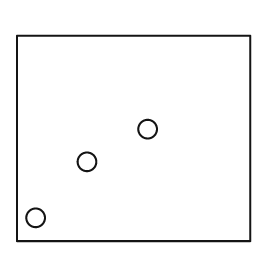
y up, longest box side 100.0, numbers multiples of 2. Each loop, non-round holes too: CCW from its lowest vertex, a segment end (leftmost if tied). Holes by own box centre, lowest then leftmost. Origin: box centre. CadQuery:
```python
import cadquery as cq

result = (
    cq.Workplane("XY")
    .moveTo(-50.0, -44.0)
    .lineTo(50.0, -44.0)
    .lineTo(50.0, 44.0)
    .lineTo(-50.0, 44.0)
    .close()
    .moveTo(-42.0, -34.0)
    .circle(4.0)
    .moveTo(-20.0, -10.0)
    .circle(4.0)
    .moveTo(6.0, 4.0)
    .circle(4.0)
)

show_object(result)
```